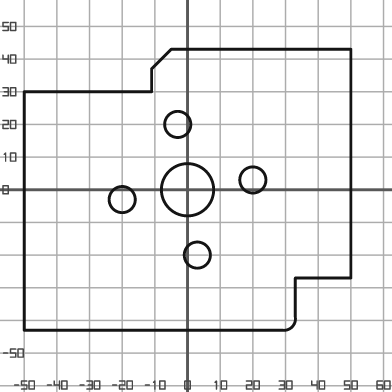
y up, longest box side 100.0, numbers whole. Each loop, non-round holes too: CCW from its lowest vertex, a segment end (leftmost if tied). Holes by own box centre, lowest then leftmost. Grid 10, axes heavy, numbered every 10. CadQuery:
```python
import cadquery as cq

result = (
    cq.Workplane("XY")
    .moveTo(-50.0, -43.0)
    .lineTo(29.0, -43.0)
    .threePointArc((32.0, -42.0), (33.0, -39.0))
    .lineTo(33.0, -27.0)
    .lineTo(50.0, -27.0)
    .lineTo(50.0, 43.0)
    .lineTo(-5.0, 43.0)
    .lineTo(-11.0, 37.0)
    .lineTo(-11.0, 30.0)
    .lineTo(-50.0, 30.0)
    .close()
    .moveTo(3.0, -20.0)
    .circle(4.0)
    .moveTo(-20.0, -3.0)
    .circle(4.0)
    .moveTo(0.0, 0.0)
    .circle(8.0)
    .moveTo(20.0, 3.0)
    .circle(4.0)
    .moveTo(-3.0, 20.0)
    .circle(4.0)
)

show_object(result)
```